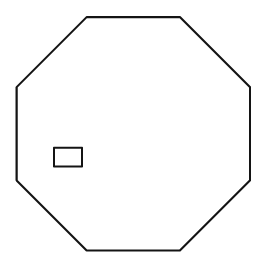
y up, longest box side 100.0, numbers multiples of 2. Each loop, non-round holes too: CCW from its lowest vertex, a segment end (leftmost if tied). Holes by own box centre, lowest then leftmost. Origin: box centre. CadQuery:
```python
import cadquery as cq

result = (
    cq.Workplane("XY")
    .moveTo(-20.0, -50.0)
    .lineTo(20.0, -50.0)
    .lineTo(50.0, -20.0)
    .lineTo(50.0, 20.0)
    .lineTo(20.0, 50.0)
    .lineTo(-20.0, 50.0)
    .lineTo(-50.0, 20.0)
    .lineTo(-50.0, -20.0)
    .close()
    .moveTo(-34.0, -14.0)
    .lineTo(-22.0, -14.0)
    .lineTo(-22.0, -6.0)
    .lineTo(-34.0, -6.0)
    .close()
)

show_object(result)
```